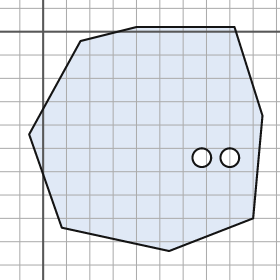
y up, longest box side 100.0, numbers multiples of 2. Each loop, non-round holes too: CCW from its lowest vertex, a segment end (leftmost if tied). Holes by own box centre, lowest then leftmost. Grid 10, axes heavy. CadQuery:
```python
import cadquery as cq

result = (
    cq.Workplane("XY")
    .moveTo(54.0, -94.0)
    .lineTo(90.0, -80.0)
    .lineTo(94.0, -36.0)
    .lineTo(82.0, 2.0)
    .lineTo(40.0, 2.0)
    .lineTo(16.0, -4.0)
    .lineTo(-6.0, -44.0)
    .lineTo(8.0, -84.0)
    .close()
    .moveTo(68.0, -54.0)
    .circle(4.0)
    .moveTo(80.0, -54.0)
    .circle(4.0)
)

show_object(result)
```